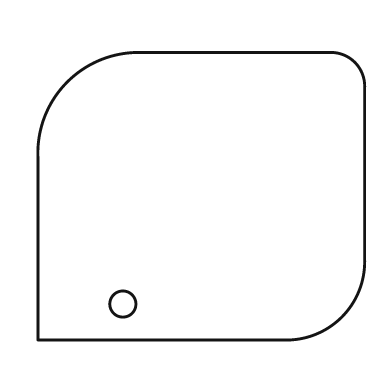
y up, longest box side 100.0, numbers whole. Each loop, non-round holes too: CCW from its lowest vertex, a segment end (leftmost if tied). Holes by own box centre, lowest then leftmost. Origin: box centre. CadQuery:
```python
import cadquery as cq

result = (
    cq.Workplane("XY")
    .moveTo(-50.0, -44.0)
    .lineTo(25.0, -44.0)
    .threePointArc((43.0, -37.0), (50.0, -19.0))
    .lineTo(50.0, 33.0)
    .threePointArc((47.0, 41.0), (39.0, 44.0))
    .lineTo(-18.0, 44.0)
    .threePointArc((-41.0, 35.0), (-50.0, 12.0))
    .close()
    .moveTo(-24.0, -33.0)
    .circle(4.0)
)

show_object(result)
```